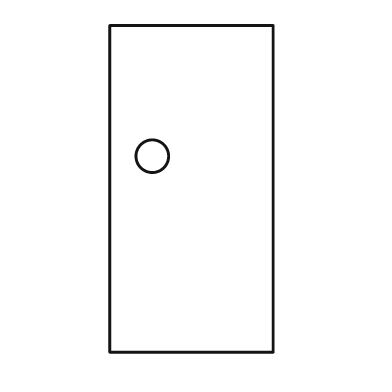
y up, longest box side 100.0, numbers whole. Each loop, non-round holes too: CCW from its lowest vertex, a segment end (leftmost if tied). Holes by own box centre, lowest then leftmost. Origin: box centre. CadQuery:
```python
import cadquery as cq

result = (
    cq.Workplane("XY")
    .moveTo(-25.0, -50.0)
    .lineTo(25.0, -50.0)
    .lineTo(25.0, 50.0)
    .lineTo(-25.0, 50.0)
    .close()
    .moveTo(-12.0, 10.0)
    .circle(5.0)
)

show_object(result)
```